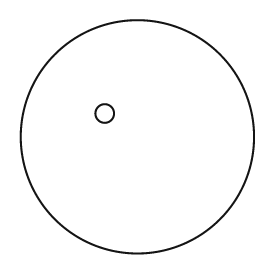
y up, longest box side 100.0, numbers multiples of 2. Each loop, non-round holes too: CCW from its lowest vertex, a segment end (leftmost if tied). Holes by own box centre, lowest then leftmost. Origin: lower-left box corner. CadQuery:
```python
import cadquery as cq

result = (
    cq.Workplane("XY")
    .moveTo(50.0, 50.0)
    .circle(50.0)
    .moveTo(36.0, 60.0)
    .circle(4.0)
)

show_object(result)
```